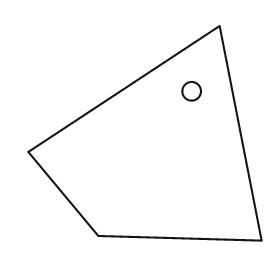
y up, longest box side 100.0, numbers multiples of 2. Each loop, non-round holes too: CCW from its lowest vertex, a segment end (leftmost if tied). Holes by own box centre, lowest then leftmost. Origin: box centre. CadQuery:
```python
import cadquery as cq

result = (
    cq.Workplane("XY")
    .moveTo(50.0, -46.0)
    .lineTo(32.0, 46.0)
    .lineTo(-50.0, -8.0)
    .lineTo(-20.0, -44.0)
    .close()
    .moveTo(20.0, 18.0)
    .circle(4.0)
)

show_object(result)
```